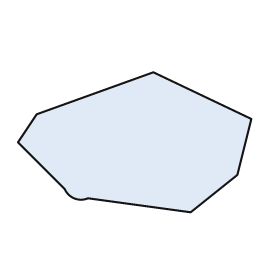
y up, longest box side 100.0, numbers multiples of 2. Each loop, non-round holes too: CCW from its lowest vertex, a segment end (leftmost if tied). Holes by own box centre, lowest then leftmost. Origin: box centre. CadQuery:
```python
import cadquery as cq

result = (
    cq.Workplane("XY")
    .moveTo(24.0, -30.0)
    .lineTo(44.0, -14.0)
    .lineTo(50.0, 10.0)
    .lineTo(8.0, 30.0)
    .lineTo(-42.0, 12.0)
    .lineTo(-50.0, 0.0)
    .lineTo(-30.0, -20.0)
    .threePointArc((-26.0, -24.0), (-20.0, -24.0))
    .close()
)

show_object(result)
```